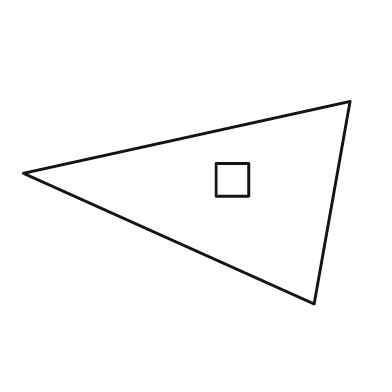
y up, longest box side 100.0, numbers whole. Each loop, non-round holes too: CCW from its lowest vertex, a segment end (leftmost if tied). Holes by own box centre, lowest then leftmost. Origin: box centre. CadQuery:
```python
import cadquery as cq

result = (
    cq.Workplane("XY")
    .moveTo(39.0, -31.0)
    .lineTo(50.0, 31.0)
    .lineTo(-50.0, 9.0)
    .close()
    .moveTo(9.0, 2.0)
    .lineTo(19.0, 2.0)
    .lineTo(19.0, 12.0)
    .lineTo(9.0, 12.0)
    .close()
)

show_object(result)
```